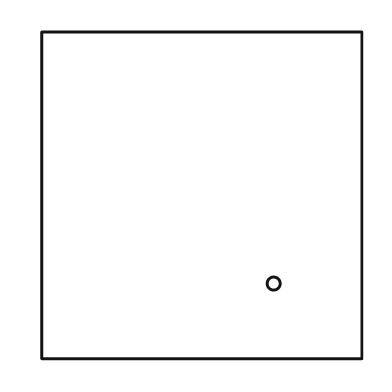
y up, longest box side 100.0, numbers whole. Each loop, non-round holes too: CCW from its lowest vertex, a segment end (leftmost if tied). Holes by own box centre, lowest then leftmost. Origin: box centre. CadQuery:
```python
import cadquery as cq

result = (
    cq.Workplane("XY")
    .moveTo(-49.0, -50.0)
    .lineTo(49.0, -50.0)
    .lineTo(49.0, 50.0)
    .lineTo(-49.0, 50.0)
    .close()
    .moveTo(22.0, -27.0)
    .circle(2.0)
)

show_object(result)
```